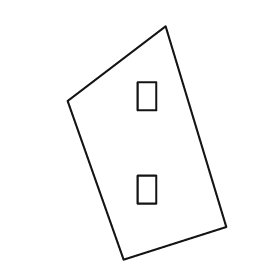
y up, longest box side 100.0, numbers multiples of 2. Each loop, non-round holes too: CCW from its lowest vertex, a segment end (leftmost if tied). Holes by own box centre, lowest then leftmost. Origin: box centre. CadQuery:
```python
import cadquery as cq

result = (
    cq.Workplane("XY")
    .moveTo(-10.0, -50.0)
    .lineTo(34.0, -36.0)
    .lineTo(8.0, 50.0)
    .lineTo(-34.0, 18.0)
    .close()
    .moveTo(-4.0, -26.0)
    .lineTo(4.0, -26.0)
    .lineTo(4.0, -14.0)
    .lineTo(-4.0, -14.0)
    .close()
    .moveTo(-4.0, 14.0)
    .lineTo(4.0, 14.0)
    .lineTo(4.0, 26.0)
    .lineTo(-4.0, 26.0)
    .close()
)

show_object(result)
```